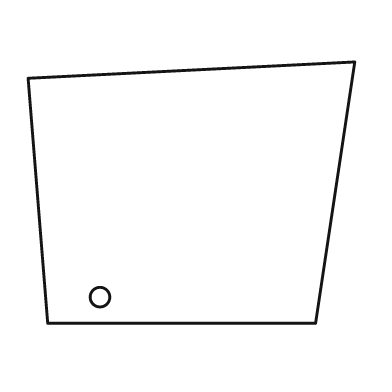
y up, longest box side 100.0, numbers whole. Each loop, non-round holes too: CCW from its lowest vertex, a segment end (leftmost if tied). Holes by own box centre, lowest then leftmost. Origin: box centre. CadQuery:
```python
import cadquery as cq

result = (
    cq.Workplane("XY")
    .moveTo(-44.0, -40.0)
    .lineTo(38.0, -40.0)
    .lineTo(50.0, 40.0)
    .lineTo(-50.0, 35.0)
    .close()
    .moveTo(-28.0, -32.0)
    .circle(3.0)
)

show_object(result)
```